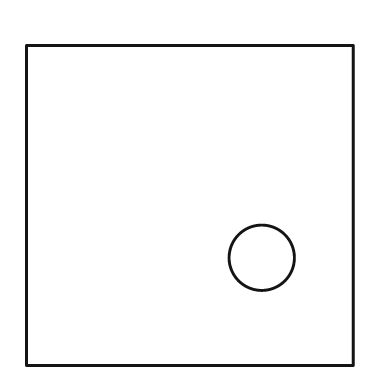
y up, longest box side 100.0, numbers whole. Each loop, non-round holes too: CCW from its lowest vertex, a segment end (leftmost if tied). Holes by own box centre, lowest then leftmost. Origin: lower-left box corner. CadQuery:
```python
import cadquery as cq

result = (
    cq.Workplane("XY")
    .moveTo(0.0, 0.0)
    .lineTo(100.0, 0.0)
    .lineTo(100.0, 98.0)
    .lineTo(0.0, 98.0)
    .close()
    .moveTo(72.0, 33.0)
    .circle(10.0)
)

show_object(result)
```